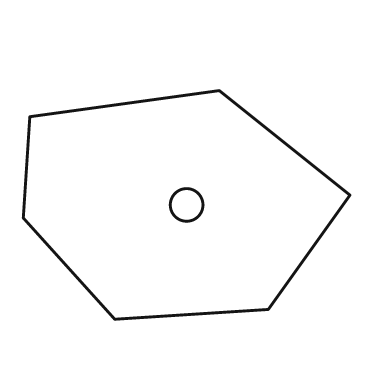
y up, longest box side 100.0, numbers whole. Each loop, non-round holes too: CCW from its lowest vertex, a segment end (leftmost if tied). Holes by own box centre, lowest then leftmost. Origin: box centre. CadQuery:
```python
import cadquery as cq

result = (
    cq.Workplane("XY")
    .moveTo(-22.0, -35.0)
    .lineTo(25.0, -32.0)
    .lineTo(50.0, 3.0)
    .lineTo(10.0, 35.0)
    .lineTo(-48.0, 27.0)
    .lineTo(-50.0, -4.0)
    .close()
    .moveTo(0.0, 0.0)
    .circle(5.0)
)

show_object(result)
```